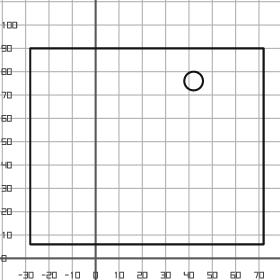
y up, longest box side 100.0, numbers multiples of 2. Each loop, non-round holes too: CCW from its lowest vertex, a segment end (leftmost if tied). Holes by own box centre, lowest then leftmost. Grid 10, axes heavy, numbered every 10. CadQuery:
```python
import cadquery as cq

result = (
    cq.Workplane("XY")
    .moveTo(-28.0, 6.0)
    .lineTo(72.0, 6.0)
    .lineTo(72.0, 90.0)
    .lineTo(-28.0, 90.0)
    .close()
    .moveTo(42.0, 76.0)
    .circle(4.0)
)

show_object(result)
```